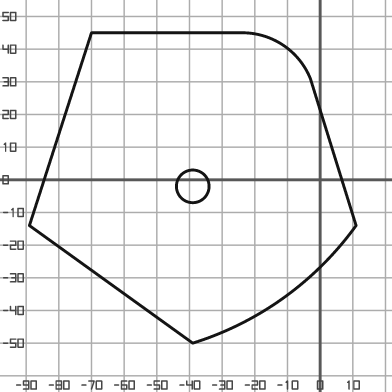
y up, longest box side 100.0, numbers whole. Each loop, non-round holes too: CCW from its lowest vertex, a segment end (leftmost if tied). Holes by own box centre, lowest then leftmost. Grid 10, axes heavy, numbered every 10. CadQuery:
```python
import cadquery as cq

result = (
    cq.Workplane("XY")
    .moveTo(-39.0, -50.0)
    .threePointArc((-11.0, -36.0), (11.0, -14.0))
    .lineTo(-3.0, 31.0)
    .threePointArc((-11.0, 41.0), (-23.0, 45.0))
    .lineTo(-70.0, 45.0)
    .lineTo(-89.0, -14.0)
    .close()
    .moveTo(-39.0, -2.0)
    .circle(5.0)
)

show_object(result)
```